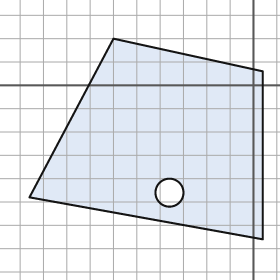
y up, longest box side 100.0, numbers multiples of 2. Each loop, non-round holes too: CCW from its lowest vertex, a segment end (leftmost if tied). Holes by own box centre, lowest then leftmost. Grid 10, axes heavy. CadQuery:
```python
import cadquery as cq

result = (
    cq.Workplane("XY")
    .moveTo(4.0, -66.0)
    .lineTo(4.0, 6.0)
    .lineTo(-60.0, 20.0)
    .lineTo(-96.0, -48.0)
    .close()
    .moveTo(-36.0, -46.0)
    .circle(6.0)
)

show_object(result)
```